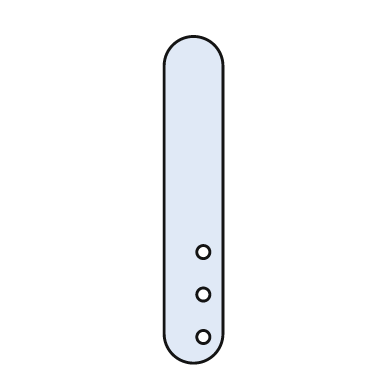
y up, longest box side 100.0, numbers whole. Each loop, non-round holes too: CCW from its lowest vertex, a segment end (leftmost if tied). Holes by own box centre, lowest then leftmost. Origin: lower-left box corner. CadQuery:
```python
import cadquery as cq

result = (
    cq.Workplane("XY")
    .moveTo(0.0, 9.0)
    .threePointArc((9.0, 0.0), (18.0, 9.0))
    .lineTo(18.0, 91.0)
    .threePointArc((9.0, 100.0), (0.0, 91.0))
    .close()
    .moveTo(12.0, 8.0)
    .circle(2.0)
    .moveTo(12.0, 21.0)
    .circle(2.0)
    .moveTo(12.0, 34.0)
    .circle(2.0)
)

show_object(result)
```